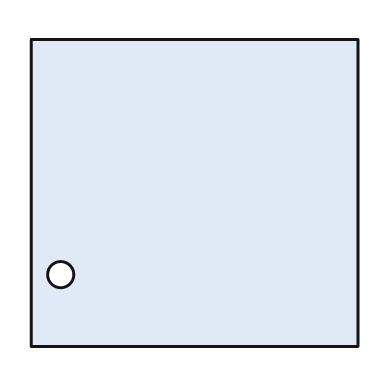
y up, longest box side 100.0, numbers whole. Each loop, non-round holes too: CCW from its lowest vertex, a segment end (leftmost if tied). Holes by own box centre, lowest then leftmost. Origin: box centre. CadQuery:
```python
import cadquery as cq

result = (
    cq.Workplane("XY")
    .moveTo(-50.0, -47.0)
    .lineTo(50.0, -47.0)
    .lineTo(50.0, 47.0)
    .lineTo(-50.0, 47.0)
    .close()
    .moveTo(-41.0, -25.0)
    .circle(4.0)
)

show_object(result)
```